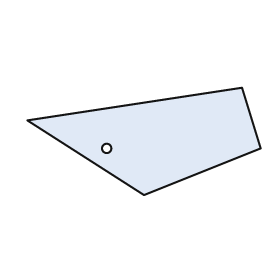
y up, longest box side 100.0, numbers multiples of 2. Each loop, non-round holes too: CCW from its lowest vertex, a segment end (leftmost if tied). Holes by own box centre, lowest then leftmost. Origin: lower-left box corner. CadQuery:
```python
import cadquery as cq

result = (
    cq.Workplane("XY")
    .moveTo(50.0, 0.0)
    .lineTo(100.0, 20.0)
    .lineTo(92.0, 46.0)
    .lineTo(0.0, 32.0)
    .close()
    .moveTo(34.0, 20.0)
    .circle(2.0)
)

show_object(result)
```